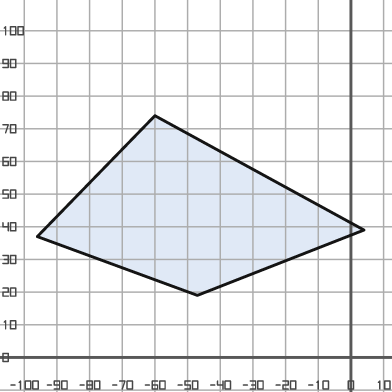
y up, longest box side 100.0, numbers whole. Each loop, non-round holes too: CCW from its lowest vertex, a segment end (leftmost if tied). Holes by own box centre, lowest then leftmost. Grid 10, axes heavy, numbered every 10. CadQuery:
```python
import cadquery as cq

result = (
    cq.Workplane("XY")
    .moveTo(-47.0, 19.0)
    .lineTo(4.0, 39.0)
    .lineTo(-60.0, 74.0)
    .lineTo(-96.0, 37.0)
    .close()
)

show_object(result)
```